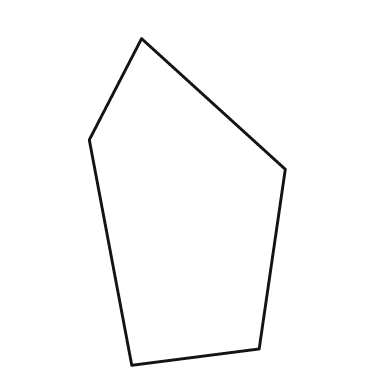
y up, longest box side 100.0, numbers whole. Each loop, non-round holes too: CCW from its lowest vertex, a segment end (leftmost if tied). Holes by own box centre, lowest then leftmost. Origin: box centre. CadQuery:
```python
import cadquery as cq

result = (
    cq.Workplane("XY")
    .moveTo(-17.0, -50.0)
    .lineTo(22.0, -45.0)
    .lineTo(30.0, 10.0)
    .lineTo(-14.0, 50.0)
    .lineTo(-30.0, 19.0)
    .close()
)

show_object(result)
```